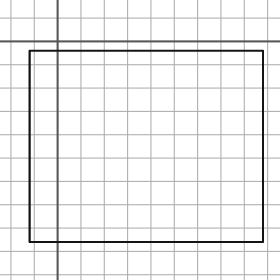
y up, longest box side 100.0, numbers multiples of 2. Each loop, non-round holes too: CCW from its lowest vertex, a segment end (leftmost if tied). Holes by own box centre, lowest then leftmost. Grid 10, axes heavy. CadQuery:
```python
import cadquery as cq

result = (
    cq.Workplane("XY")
    .moveTo(-12.0, -86.0)
    .lineTo(88.0, -86.0)
    .lineTo(88.0, -4.0)
    .lineTo(-12.0, -4.0)
    .close()
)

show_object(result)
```